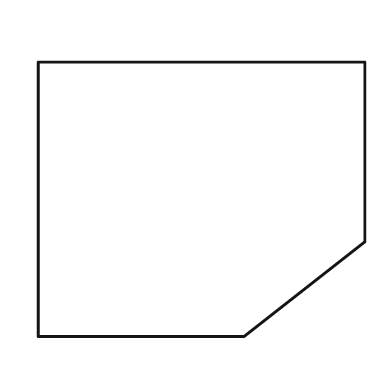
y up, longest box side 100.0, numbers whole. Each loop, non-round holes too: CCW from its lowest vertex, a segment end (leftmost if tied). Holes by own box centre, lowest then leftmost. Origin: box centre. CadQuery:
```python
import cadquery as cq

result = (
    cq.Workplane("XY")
    .moveTo(-50.0, -42.0)
    .lineTo(13.0, -42.0)
    .lineTo(50.0, -13.0)
    .lineTo(50.0, 42.0)
    .lineTo(-50.0, 42.0)
    .close()
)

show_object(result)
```